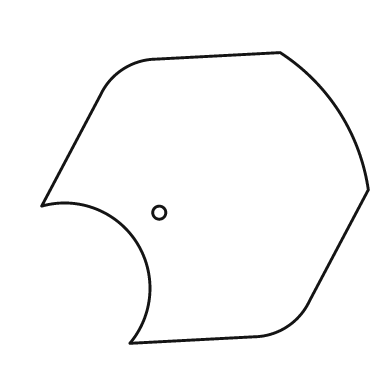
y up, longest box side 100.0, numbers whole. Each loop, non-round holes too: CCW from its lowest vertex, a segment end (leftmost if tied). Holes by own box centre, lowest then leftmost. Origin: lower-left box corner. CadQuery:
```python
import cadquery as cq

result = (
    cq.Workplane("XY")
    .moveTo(27.0, 0.0)
    .lineTo(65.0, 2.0)
    .threePointArc((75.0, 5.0), (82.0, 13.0))
    .lineTo(100.0, 47.0)
    .threePointArc((91.0, 71.0), (73.0, 89.0))
    .lineTo(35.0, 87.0)
    .threePointArc((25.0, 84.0), (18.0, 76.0))
    .lineTo(0.0, 42.0)
    .threePointArc((29.0, 31.0), (27.0, 0.0))
    .close()
    .moveTo(36.0, 40.0)
    .circle(2.0)
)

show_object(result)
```